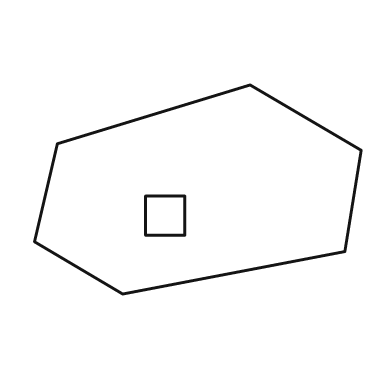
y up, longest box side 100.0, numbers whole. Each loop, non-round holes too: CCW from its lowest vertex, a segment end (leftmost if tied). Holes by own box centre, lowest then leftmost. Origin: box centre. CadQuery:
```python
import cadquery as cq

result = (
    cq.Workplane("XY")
    .moveTo(-23.0, -32.0)
    .lineTo(45.0, -19.0)
    .lineTo(50.0, 12.0)
    .lineTo(16.0, 32.0)
    .lineTo(-43.0, 14.0)
    .lineTo(-50.0, -16.0)
    .close()
    .moveTo(-16.0, -14.0)
    .lineTo(-4.0, -14.0)
    .lineTo(-4.0, -2.0)
    .lineTo(-16.0, -2.0)
    .close()
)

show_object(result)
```